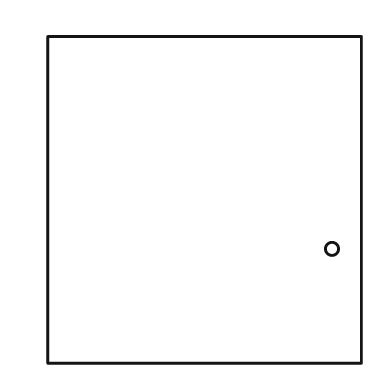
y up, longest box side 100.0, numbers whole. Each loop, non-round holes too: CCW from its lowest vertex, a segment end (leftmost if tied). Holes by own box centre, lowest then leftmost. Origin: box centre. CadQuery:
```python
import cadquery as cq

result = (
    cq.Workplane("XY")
    .moveTo(-48.0, -50.0)
    .lineTo(48.0, -50.0)
    .lineTo(48.0, 50.0)
    .lineTo(-48.0, 50.0)
    .close()
    .moveTo(39.0, -15.0)
    .circle(2.0)
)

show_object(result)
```